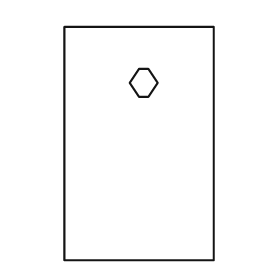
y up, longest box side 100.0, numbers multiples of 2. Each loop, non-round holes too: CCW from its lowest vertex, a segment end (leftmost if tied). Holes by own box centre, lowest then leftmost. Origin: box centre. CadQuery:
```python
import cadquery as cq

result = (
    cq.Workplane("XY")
    .moveTo(-32.0, -50.0)
    .lineTo(32.0, -50.0)
    .lineTo(32.0, 50.0)
    .lineTo(-32.0, 50.0)
    .close()
    .moveTo(0.0, 20.0)
    .lineTo(4.0, 20.0)
    .lineTo(8.0, 26.0)
    .lineTo(4.0, 32.0)
    .lineTo(0.0, 32.0)
    .lineTo(-4.0, 26.0)
    .close()
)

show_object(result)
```